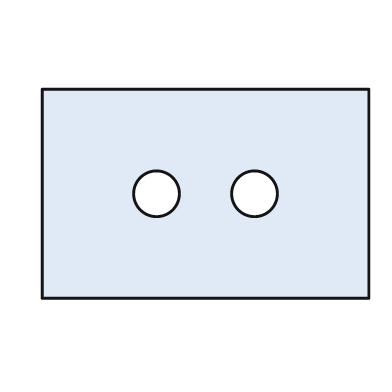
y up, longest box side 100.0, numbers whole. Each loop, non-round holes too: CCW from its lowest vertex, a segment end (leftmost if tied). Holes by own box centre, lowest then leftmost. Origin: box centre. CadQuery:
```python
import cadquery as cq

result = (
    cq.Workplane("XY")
    .moveTo(-50.0, -32.0)
    .lineTo(50.0, -32.0)
    .lineTo(50.0, 32.0)
    .lineTo(-50.0, 32.0)
    .close()
    .moveTo(-15.0, 0.0)
    .circle(7.0)
    .moveTo(15.0, 0.0)
    .circle(7.0)
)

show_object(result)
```